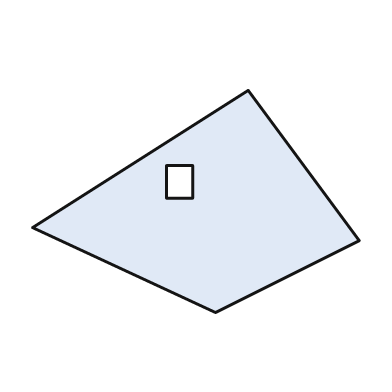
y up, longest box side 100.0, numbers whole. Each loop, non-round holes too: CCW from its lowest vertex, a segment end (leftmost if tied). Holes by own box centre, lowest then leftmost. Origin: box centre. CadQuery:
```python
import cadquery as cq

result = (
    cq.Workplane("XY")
    .moveTo(6.0, -34.0)
    .lineTo(50.0, -12.0)
    .lineTo(16.0, 34.0)
    .lineTo(-50.0, -8.0)
    .close()
    .moveTo(-9.0, 1.0)
    .lineTo(-1.0, 1.0)
    .lineTo(-1.0, 11.0)
    .lineTo(-9.0, 11.0)
    .close()
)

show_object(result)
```